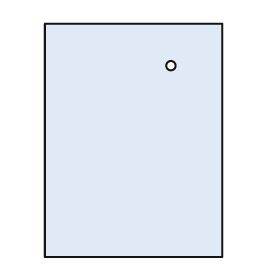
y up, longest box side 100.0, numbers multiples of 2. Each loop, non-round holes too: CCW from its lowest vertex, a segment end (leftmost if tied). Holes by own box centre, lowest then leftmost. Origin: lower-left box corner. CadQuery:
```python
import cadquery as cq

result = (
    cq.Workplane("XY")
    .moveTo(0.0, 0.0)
    .lineTo(76.0, 0.0)
    .lineTo(76.0, 100.0)
    .lineTo(0.0, 100.0)
    .close()
    .moveTo(54.0, 82.0)
    .circle(2.0)
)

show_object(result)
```